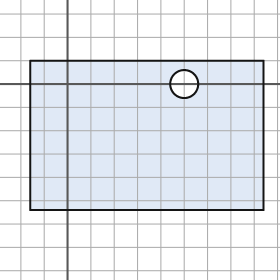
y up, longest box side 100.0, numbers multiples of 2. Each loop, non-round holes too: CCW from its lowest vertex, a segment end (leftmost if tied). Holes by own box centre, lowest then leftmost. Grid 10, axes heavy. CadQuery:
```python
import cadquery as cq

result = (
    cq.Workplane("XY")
    .moveTo(-16.0, -54.0)
    .lineTo(84.0, -54.0)
    .lineTo(84.0, 10.0)
    .lineTo(-16.0, 10.0)
    .close()
    .moveTo(50.0, 0.0)
    .circle(6.0)
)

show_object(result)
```